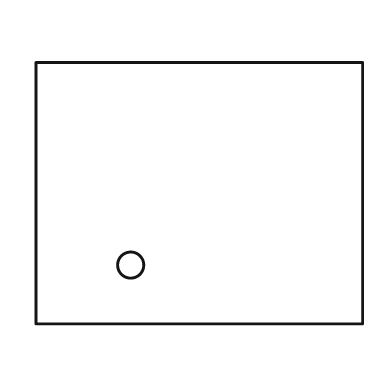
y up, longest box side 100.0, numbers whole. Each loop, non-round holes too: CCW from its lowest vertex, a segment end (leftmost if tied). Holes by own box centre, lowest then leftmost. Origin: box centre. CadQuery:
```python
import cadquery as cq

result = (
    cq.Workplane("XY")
    .moveTo(-50.0, -40.0)
    .lineTo(50.0, -40.0)
    .lineTo(50.0, 40.0)
    .lineTo(-50.0, 40.0)
    .close()
    .moveTo(-21.0, -22.0)
    .circle(4.0)
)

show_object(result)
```